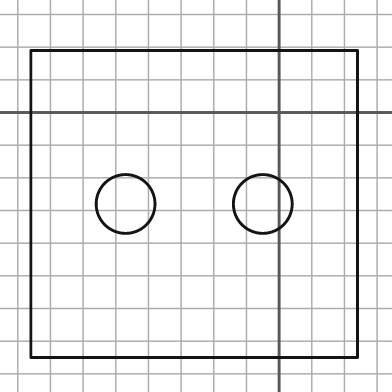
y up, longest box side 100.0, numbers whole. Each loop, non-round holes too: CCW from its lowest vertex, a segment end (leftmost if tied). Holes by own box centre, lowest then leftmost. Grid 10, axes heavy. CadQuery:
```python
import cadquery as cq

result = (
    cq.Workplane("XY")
    .moveTo(-76.0, -75.0)
    .lineTo(24.0, -75.0)
    .lineTo(24.0, 19.0)
    .lineTo(-76.0, 19.0)
    .close()
    .moveTo(-47.0, -28.0)
    .circle(9.0)
    .moveTo(-5.0, -28.0)
    .circle(9.0)
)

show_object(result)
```